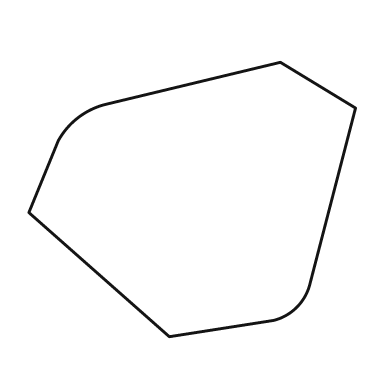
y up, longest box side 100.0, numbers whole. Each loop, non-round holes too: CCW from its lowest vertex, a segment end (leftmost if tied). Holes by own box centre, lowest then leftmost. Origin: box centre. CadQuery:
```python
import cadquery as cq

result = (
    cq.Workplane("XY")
    .moveTo(-7.0, -42.0)
    .lineTo(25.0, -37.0)
    .threePointArc((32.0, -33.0), (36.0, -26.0))
    .lineTo(50.0, 28.0)
    .lineTo(27.0, 42.0)
    .lineTo(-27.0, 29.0)
    .threePointArc((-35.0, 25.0), (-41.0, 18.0))
    .lineTo(-50.0, -4.0)
    .close()
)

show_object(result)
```